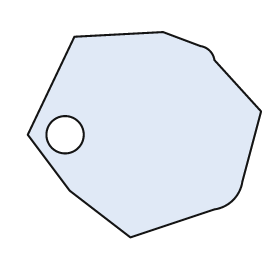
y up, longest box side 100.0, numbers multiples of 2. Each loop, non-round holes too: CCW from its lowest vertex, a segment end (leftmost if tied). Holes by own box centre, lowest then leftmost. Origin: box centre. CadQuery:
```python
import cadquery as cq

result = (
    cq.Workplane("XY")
    .moveTo(-6.0, -44.0)
    .lineTo(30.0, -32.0)
    .threePointArc((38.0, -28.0), (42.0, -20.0))
    .lineTo(50.0, 10.0)
    .lineTo(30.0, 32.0)
    .threePointArc((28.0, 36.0), (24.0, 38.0))
    .lineTo(8.0, 44.0)
    .lineTo(-30.0, 42.0)
    .lineTo(-50.0, 0.0)
    .lineTo(-32.0, -24.0)
    .close()
    .moveTo(-34.0, 0.0)
    .circle(8.0)
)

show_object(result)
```